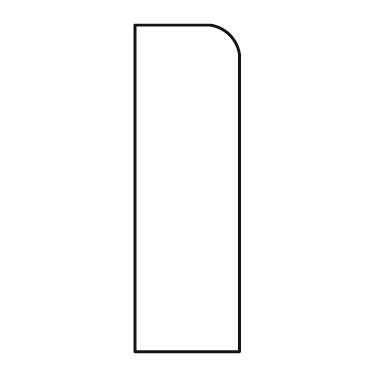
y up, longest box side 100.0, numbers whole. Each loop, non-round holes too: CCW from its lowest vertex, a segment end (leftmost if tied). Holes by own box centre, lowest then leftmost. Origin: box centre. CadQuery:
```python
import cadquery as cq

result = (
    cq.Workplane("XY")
    .moveTo(-16.0, -50.0)
    .lineTo(16.0, -50.0)
    .lineTo(16.0, 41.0)
    .threePointArc((13.0, 47.0), (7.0, 50.0))
    .lineTo(-16.0, 50.0)
    .close()
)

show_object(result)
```